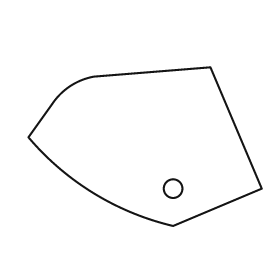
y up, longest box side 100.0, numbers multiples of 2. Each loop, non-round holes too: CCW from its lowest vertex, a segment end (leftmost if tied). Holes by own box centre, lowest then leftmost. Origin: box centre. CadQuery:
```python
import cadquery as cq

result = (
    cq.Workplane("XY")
    .moveTo(12.0, -34.0)
    .lineTo(50.0, -18.0)
    .lineTo(28.0, 34.0)
    .lineTo(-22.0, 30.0)
    .threePointArc((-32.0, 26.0), (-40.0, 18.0))
    .lineTo(-50.0, 4.0)
    .threePointArc((-22.0, -20.0), (12.0, -34.0))
    .close()
    .moveTo(12.0, -18.0)
    .circle(4.0)
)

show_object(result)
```